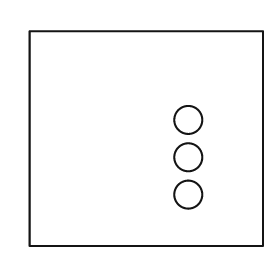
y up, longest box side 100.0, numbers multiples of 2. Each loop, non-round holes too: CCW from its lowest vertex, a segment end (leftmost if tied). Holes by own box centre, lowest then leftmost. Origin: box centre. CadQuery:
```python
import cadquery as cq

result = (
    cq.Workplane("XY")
    .moveTo(-50.0, -46.0)
    .lineTo(50.0, -46.0)
    .lineTo(50.0, 46.0)
    .lineTo(-50.0, 46.0)
    .close()
    .moveTo(18.0, -24.0)
    .circle(6.0)
    .moveTo(18.0, -8.0)
    .circle(6.0)
    .moveTo(18.0, 8.0)
    .circle(6.0)
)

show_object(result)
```